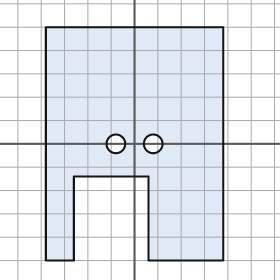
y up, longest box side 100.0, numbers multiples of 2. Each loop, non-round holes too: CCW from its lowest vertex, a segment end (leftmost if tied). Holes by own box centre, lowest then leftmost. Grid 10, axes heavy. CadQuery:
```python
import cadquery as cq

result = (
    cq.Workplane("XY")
    .moveTo(-38.0, -50.0)
    .lineTo(-26.0, -50.0)
    .lineTo(-26.0, -14.0)
    .lineTo(6.0, -14.0)
    .lineTo(6.0, -50.0)
    .lineTo(38.0, -50.0)
    .lineTo(38.0, 50.0)
    .lineTo(-38.0, 50.0)
    .close()
    .moveTo(-8.0, 0.0)
    .circle(4.0)
    .moveTo(8.0, 0.0)
    .circle(4.0)
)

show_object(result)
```